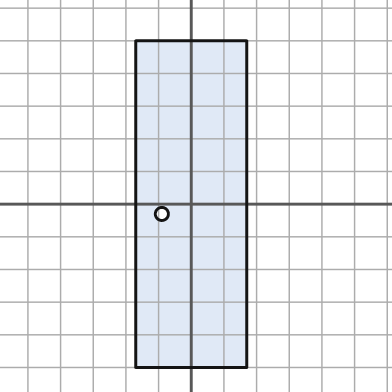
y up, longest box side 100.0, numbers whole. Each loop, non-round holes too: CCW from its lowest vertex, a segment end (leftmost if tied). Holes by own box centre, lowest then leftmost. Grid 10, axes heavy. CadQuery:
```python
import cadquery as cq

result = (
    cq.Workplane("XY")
    .moveTo(-17.0, -50.0)
    .lineTo(17.0, -50.0)
    .lineTo(17.0, 50.0)
    .lineTo(-17.0, 50.0)
    .close()
    .moveTo(-9.0, -3.0)
    .circle(2.0)
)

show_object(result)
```